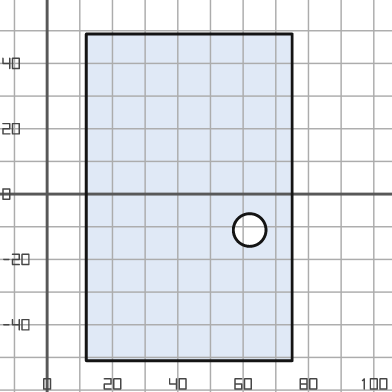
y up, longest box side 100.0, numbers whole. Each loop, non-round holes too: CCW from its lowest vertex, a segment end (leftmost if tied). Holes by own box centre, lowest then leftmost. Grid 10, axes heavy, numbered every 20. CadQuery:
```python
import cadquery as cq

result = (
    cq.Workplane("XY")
    .moveTo(12.0, -51.0)
    .lineTo(75.0, -51.0)
    .lineTo(75.0, 49.0)
    .lineTo(12.0, 49.0)
    .close()
    .moveTo(62.0, -11.0)
    .circle(5.0)
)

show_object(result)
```